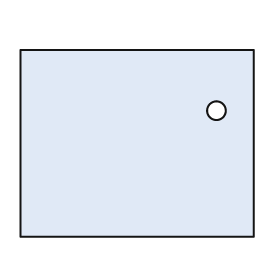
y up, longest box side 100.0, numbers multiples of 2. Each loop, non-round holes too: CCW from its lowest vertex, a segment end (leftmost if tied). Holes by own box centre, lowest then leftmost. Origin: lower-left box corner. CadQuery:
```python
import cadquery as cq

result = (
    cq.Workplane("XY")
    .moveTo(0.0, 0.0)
    .lineTo(100.0, 0.0)
    .lineTo(100.0, 80.0)
    .lineTo(0.0, 80.0)
    .close()
    .moveTo(84.0, 54.0)
    .circle(4.0)
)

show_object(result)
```